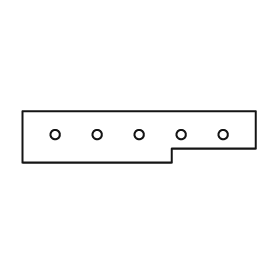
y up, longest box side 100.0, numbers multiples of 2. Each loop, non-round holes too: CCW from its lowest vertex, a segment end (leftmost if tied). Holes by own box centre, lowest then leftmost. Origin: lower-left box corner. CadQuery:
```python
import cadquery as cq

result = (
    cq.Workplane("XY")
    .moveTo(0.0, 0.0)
    .lineTo(64.0, 0.0)
    .lineTo(64.0, 6.0)
    .lineTo(100.0, 6.0)
    .lineTo(100.0, 22.0)
    .lineTo(0.0, 22.0)
    .close()
    .moveTo(14.0, 12.0)
    .circle(2.0)
    .moveTo(32.0, 12.0)
    .circle(2.0)
    .moveTo(50.0, 12.0)
    .circle(2.0)
    .moveTo(68.0, 12.0)
    .circle(2.0)
    .moveTo(86.0, 12.0)
    .circle(2.0)
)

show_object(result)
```